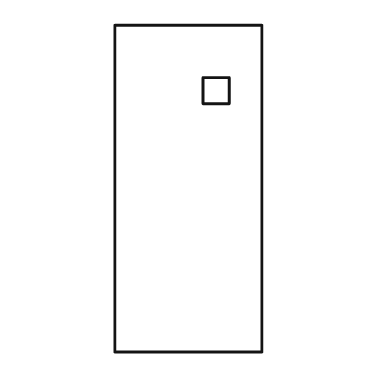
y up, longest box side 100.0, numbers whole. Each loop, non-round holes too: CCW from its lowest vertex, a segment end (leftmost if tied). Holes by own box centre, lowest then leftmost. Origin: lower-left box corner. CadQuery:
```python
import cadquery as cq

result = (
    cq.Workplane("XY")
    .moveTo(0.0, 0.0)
    .lineTo(45.0, 0.0)
    .lineTo(45.0, 100.0)
    .lineTo(0.0, 100.0)
    .close()
    .moveTo(27.0, 76.0)
    .lineTo(35.0, 76.0)
    .lineTo(35.0, 84.0)
    .lineTo(27.0, 84.0)
    .close()
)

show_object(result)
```